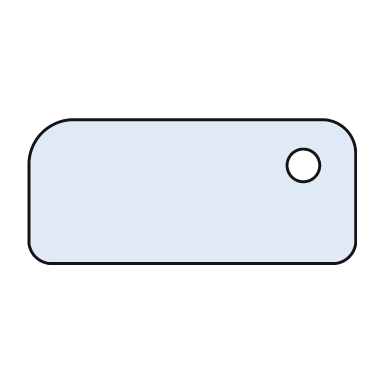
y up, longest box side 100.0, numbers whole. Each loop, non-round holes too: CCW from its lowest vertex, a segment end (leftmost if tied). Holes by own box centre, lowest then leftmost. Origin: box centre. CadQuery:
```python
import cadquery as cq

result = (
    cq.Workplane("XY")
    .moveTo(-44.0, -22.0)
    .lineTo(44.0, -22.0)
    .threePointArc((48.0, -20.0), (50.0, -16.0))
    .lineTo(50.0, 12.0)
    .threePointArc((47.0, 19.0), (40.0, 22.0))
    .lineTo(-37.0, 22.0)
    .threePointArc((-46.0, 18.0), (-50.0, 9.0))
    .lineTo(-50.0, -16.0)
    .threePointArc((-48.0, -20.0), (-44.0, -22.0))
    .close()
    .moveTo(34.0, 8.0)
    .circle(5.0)
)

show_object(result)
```